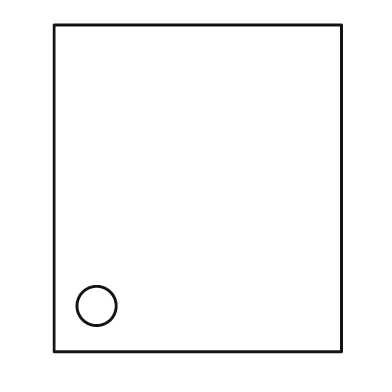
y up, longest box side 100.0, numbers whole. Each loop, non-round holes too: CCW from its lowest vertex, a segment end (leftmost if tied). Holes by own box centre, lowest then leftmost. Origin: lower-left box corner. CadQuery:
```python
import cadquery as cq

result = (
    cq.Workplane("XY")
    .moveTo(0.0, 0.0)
    .lineTo(88.0, 0.0)
    .lineTo(88.0, 100.0)
    .lineTo(0.0, 100.0)
    .close()
    .moveTo(13.0, 14.0)
    .circle(6.0)
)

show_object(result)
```